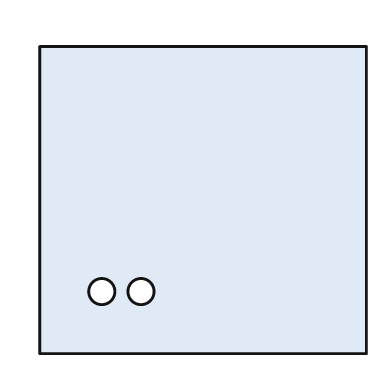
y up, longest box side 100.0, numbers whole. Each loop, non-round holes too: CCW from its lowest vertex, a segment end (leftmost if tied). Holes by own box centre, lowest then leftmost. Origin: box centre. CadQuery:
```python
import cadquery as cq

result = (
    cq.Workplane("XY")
    .moveTo(-50.0, -47.0)
    .lineTo(50.0, -47.0)
    .lineTo(50.0, 47.0)
    .lineTo(-50.0, 47.0)
    .close()
    .moveTo(-31.0, -28.0)
    .circle(4.0)
    .moveTo(-19.0, -28.0)
    .circle(4.0)
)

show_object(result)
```